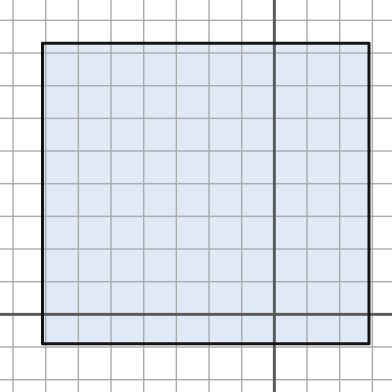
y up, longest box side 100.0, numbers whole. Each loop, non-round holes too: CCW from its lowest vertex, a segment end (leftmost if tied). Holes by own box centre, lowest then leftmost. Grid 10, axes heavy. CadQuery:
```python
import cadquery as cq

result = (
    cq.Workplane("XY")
    .moveTo(-71.0, -9.0)
    .lineTo(29.0, -9.0)
    .lineTo(29.0, 83.0)
    .lineTo(-71.0, 83.0)
    .close()
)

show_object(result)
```